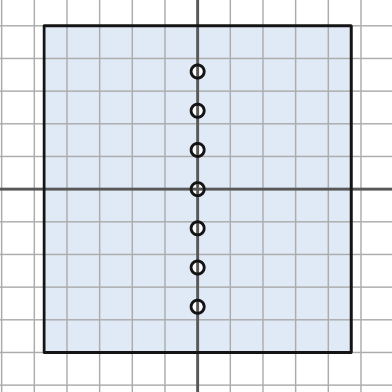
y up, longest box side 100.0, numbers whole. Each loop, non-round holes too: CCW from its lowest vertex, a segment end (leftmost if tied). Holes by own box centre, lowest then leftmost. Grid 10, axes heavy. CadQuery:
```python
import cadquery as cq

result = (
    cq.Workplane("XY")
    .moveTo(-47.0, -50.0)
    .lineTo(47.0, -50.0)
    .lineTo(47.0, 50.0)
    .lineTo(-47.0, 50.0)
    .close()
    .moveTo(0.0, -36.0)
    .circle(2.0)
    .moveTo(0.0, -24.0)
    .circle(2.0)
    .moveTo(0.0, -12.0)
    .circle(2.0)
    .moveTo(0.0, 0.0)
    .circle(2.0)
    .moveTo(0.0, 12.0)
    .circle(2.0)
    .moveTo(0.0, 24.0)
    .circle(2.0)
    .moveTo(0.0, 36.0)
    .circle(2.0)
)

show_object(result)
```